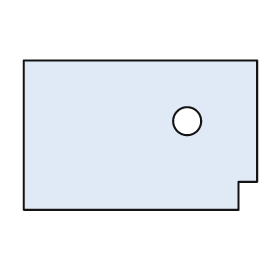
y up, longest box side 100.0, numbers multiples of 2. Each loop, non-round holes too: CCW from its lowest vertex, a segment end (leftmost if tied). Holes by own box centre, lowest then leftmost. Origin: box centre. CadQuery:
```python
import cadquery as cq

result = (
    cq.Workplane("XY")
    .moveTo(-50.0, -32.0)
    .lineTo(42.0, -32.0)
    .lineTo(42.0, -20.0)
    .lineTo(50.0, -20.0)
    .lineTo(50.0, 32.0)
    .lineTo(-50.0, 32.0)
    .close()
    .moveTo(20.0, 6.0)
    .circle(6.0)
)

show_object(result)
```